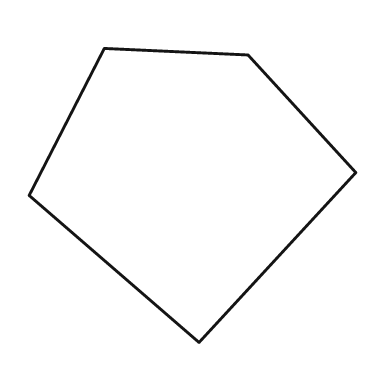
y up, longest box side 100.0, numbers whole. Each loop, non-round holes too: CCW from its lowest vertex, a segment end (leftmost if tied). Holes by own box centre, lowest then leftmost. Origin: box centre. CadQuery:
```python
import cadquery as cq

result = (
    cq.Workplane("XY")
    .moveTo(2.0, -45.0)
    .lineTo(50.0, 7.0)
    .lineTo(17.0, 43.0)
    .lineTo(-27.0, 45.0)
    .lineTo(-50.0, 0.0)
    .close()
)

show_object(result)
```